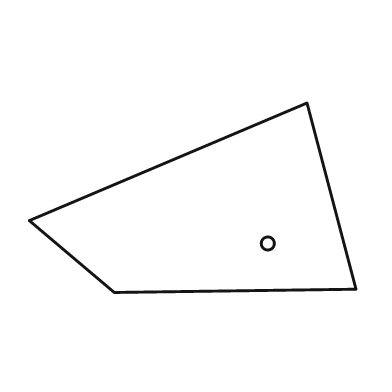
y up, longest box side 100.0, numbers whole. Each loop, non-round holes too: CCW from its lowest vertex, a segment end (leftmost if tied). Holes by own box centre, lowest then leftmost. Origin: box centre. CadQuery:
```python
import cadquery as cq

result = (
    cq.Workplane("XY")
    .moveTo(-24.0, -29.0)
    .lineTo(50.0, -28.0)
    .lineTo(35.0, 29.0)
    .lineTo(-50.0, -7.0)
    .close()
    .moveTo(23.0, -14.0)
    .circle(2.0)
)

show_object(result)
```